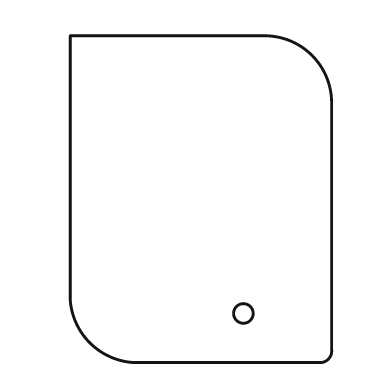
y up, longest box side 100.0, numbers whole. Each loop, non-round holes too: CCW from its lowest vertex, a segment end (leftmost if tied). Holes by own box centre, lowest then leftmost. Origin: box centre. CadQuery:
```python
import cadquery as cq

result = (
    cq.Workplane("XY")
    .moveTo(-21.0, -50.0)
    .lineTo(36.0, -50.0)
    .threePointArc((39.0, -49.0), (40.0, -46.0))
    .lineTo(40.0, 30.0)
    .threePointArc((34.0, 44.0), (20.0, 50.0))
    .lineTo(-40.0, 50.0)
    .lineTo(-40.0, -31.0)
    .threePointArc((-34.0, -44.0), (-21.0, -50.0))
    .close()
    .moveTo(13.0, -35.0)
    .circle(3.0)
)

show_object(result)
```